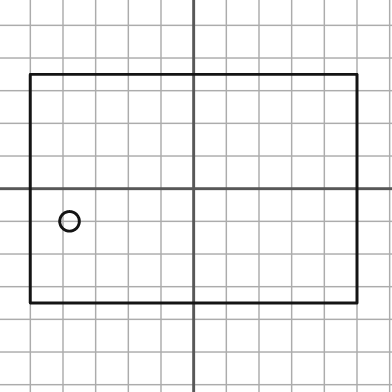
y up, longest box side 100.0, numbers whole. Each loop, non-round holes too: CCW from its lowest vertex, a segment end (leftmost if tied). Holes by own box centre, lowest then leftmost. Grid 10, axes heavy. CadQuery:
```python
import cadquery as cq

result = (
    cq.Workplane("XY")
    .moveTo(-50.0, -35.0)
    .lineTo(50.0, -35.0)
    .lineTo(50.0, 35.0)
    .lineTo(-50.0, 35.0)
    .close()
    .moveTo(-38.0, -10.0)
    .circle(3.0)
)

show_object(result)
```